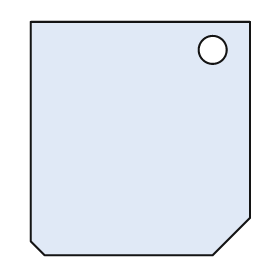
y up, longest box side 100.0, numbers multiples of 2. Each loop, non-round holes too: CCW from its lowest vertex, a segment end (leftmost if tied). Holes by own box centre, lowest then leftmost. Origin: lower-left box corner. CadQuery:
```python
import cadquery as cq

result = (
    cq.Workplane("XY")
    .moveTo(6.0, 0.0)
    .lineTo(78.0, 0.0)
    .lineTo(94.0, 16.0)
    .lineTo(94.0, 100.0)
    .lineTo(0.0, 100.0)
    .lineTo(0.0, 6.0)
    .close()
    .moveTo(78.0, 88.0)
    .circle(6.0)
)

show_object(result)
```